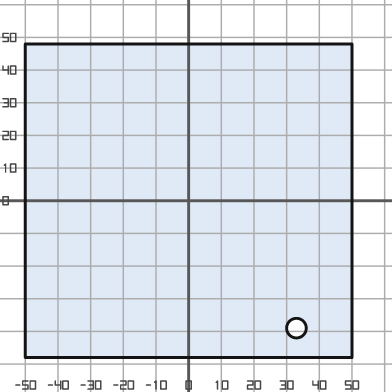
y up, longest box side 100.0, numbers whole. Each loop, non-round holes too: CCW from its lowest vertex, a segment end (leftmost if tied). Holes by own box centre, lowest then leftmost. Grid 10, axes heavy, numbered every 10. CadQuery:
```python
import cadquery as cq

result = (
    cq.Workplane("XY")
    .moveTo(-50.0, -48.0)
    .lineTo(50.0, -48.0)
    .lineTo(50.0, 48.0)
    .lineTo(-50.0, 48.0)
    .close()
    .moveTo(33.0, -39.0)
    .circle(3.0)
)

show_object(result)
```